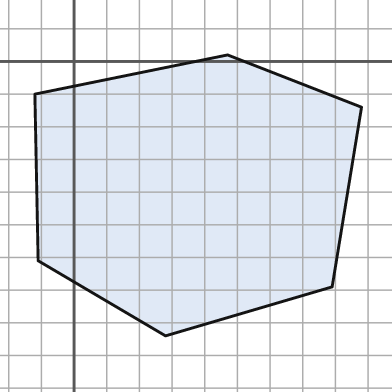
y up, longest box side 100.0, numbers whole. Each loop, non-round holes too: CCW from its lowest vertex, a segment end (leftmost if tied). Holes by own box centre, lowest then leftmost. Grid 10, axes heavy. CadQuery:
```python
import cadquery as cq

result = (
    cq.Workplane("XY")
    .moveTo(28.0, -84.0)
    .lineTo(79.0, -69.0)
    .lineTo(88.0, -14.0)
    .lineTo(47.0, 2.0)
    .lineTo(-12.0, -10.0)
    .lineTo(-11.0, -61.0)
    .close()
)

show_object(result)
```